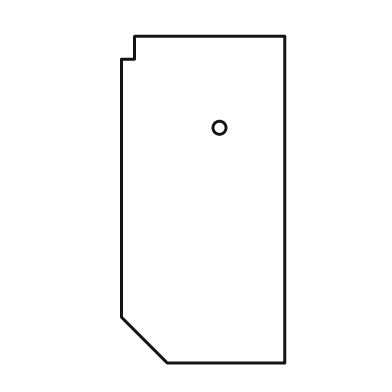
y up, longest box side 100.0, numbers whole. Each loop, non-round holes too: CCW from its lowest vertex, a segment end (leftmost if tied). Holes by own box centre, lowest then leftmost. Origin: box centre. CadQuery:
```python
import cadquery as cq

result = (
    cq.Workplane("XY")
    .moveTo(-11.0, -50.0)
    .lineTo(25.0, -50.0)
    .lineTo(25.0, 50.0)
    .lineTo(-21.0, 50.0)
    .lineTo(-21.0, 43.0)
    .lineTo(-25.0, 43.0)
    .lineTo(-25.0, -36.0)
    .close()
    .moveTo(5.0, 22.0)
    .circle(2.0)
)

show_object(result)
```